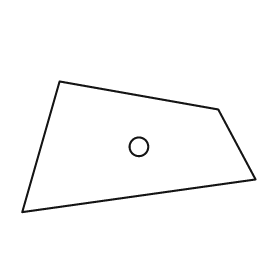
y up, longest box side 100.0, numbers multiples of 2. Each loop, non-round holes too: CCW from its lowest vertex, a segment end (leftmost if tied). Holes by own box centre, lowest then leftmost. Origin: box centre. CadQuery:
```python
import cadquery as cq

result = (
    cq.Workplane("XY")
    .moveTo(-50.0, -28.0)
    .lineTo(50.0, -14.0)
    .lineTo(34.0, 16.0)
    .lineTo(-34.0, 28.0)
    .close()
    .moveTo(0.0, 0.0)
    .circle(4.0)
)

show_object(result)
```